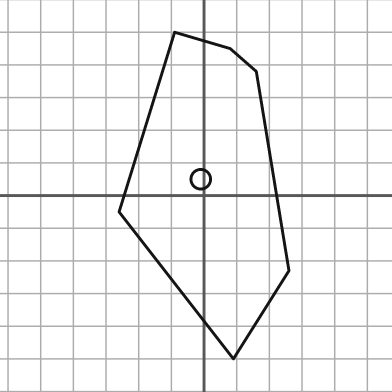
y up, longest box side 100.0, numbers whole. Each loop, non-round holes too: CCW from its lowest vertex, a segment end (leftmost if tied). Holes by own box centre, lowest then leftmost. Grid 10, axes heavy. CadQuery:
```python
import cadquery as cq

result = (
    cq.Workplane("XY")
    .moveTo(9.0, -50.0)
    .lineTo(26.0, -23.0)
    .lineTo(16.0, 38.0)
    .lineTo(8.0, 45.0)
    .lineTo(-9.0, 50.0)
    .lineTo(-26.0, -5.0)
    .close()
    .moveTo(-1.0, 5.0)
    .circle(3.0)
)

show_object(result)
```